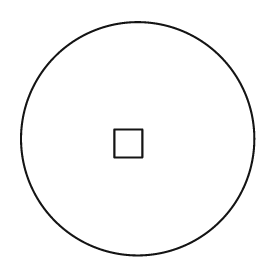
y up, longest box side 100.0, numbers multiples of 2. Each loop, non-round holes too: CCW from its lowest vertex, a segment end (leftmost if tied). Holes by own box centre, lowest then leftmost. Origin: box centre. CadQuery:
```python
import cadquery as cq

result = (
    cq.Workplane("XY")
    .moveTo(0.0, 0.0)
    .circle(50.0)
    .moveTo(-10.0, -8.0)
    .lineTo(2.0, -8.0)
    .lineTo(2.0, 4.0)
    .lineTo(-10.0, 4.0)
    .close()
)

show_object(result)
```